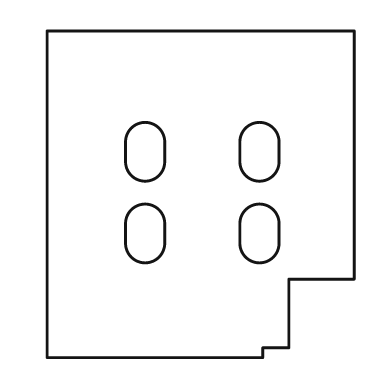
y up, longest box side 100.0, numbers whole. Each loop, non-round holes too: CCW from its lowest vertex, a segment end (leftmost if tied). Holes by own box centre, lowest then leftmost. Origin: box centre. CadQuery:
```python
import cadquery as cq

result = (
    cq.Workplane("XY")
    .moveTo(-47.0, -50.0)
    .lineTo(19.0, -50.0)
    .lineTo(19.0, -47.0)
    .lineTo(27.0, -47.0)
    .lineTo(27.0, -26.0)
    .lineTo(47.0, -26.0)
    .lineTo(47.0, 50.0)
    .lineTo(-47.0, 50.0)
    .close()
    .moveTo(-23.0, -15.0)
    .threePointArc((-17.0, -21.0), (-11.0, -15.0))
    .lineTo(-11.0, -9.0)
    .threePointArc((-17.0, -3.0), (-23.0, -9.0))
    .close()
    .moveTo(12.0, -15.0)
    .threePointArc((18.0, -21.0), (24.0, -15.0))
    .lineTo(24.0, -9.0)
    .threePointArc((18.0, -3.0), (12.0, -9.0))
    .close()
    .moveTo(-23.0, 10.0)
    .threePointArc((-17.0, 4.0), (-11.0, 10.0))
    .lineTo(-11.0, 16.0)
    .threePointArc((-17.0, 22.0), (-23.0, 16.0))
    .close()
    .moveTo(12.0, 10.0)
    .threePointArc((18.0, 4.0), (24.0, 10.0))
    .lineTo(24.0, 16.0)
    .threePointArc((18.0, 22.0), (12.0, 16.0))
    .close()
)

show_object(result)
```